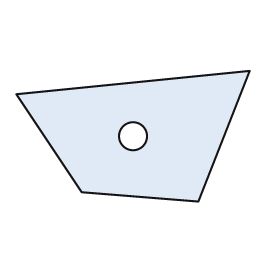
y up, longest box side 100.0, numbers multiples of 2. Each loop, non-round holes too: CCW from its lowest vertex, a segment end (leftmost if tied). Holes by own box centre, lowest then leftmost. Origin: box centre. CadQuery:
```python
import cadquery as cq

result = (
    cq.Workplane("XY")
    .moveTo(28.0, -28.0)
    .lineTo(50.0, 28.0)
    .lineTo(-50.0, 18.0)
    .lineTo(-22.0, -24.0)
    .close()
    .moveTo(0.0, 0.0)
    .circle(6.0)
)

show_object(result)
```